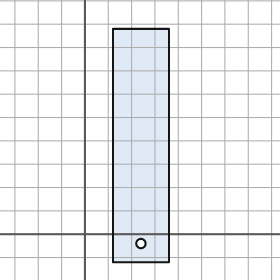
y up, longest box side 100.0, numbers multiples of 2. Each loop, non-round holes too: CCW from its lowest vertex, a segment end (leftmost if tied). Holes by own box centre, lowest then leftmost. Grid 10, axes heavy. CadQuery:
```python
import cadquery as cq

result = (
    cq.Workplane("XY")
    .moveTo(12.0, -12.0)
    .lineTo(36.0, -12.0)
    .lineTo(36.0, 88.0)
    .lineTo(12.0, 88.0)
    .close()
    .moveTo(24.0, -4.0)
    .circle(2.0)
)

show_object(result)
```